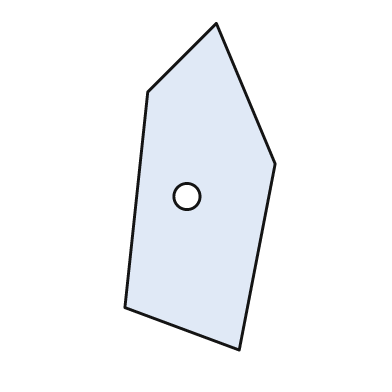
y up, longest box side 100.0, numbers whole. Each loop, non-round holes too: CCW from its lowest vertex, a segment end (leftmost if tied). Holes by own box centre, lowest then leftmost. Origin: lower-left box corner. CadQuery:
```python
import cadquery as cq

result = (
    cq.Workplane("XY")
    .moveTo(35.0, 0.0)
    .lineTo(46.0, 57.0)
    .lineTo(28.0, 100.0)
    .lineTo(7.0, 79.0)
    .lineTo(0.0, 13.0)
    .close()
    .moveTo(19.0, 47.0)
    .circle(4.0)
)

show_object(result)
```